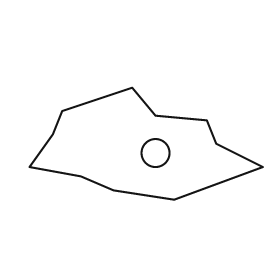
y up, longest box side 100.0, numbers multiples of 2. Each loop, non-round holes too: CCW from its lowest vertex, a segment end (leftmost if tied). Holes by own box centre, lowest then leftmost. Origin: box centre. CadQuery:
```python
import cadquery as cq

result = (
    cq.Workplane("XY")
    .moveTo(12.0, -24.0)
    .lineTo(50.0, -10.0)
    .lineTo(30.0, 0.0)
    .lineTo(26.0, 10.0)
    .lineTo(4.0, 12.0)
    .lineTo(-6.0, 24.0)
    .lineTo(-36.0, 14.0)
    .lineTo(-40.0, 4.0)
    .lineTo(-50.0, -10.0)
    .lineTo(-28.0, -14.0)
    .lineTo(-14.0, -20.0)
    .close()
    .moveTo(4.0, -4.0)
    .circle(6.0)
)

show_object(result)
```